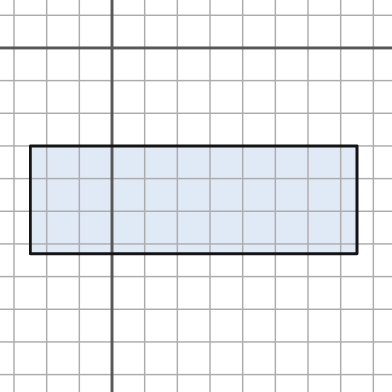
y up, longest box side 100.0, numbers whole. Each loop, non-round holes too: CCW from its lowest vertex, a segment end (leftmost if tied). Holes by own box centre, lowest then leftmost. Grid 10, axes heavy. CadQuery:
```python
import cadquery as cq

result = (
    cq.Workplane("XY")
    .moveTo(-25.0, -63.0)
    .lineTo(75.0, -63.0)
    .lineTo(75.0, -30.0)
    .lineTo(-25.0, -30.0)
    .close()
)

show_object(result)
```